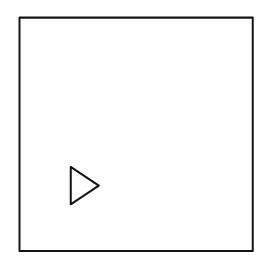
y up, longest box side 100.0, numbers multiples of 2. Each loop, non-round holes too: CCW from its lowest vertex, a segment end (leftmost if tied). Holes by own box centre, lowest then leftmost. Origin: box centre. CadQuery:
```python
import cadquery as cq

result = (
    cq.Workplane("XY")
    .moveTo(-50.0, -50.0)
    .lineTo(50.0, -50.0)
    .lineTo(50.0, 50.0)
    .lineTo(-50.0, 50.0)
    .close()
    .moveTo(-28.0, -30.0)
    .lineTo(-16.0, -22.0)
    .lineTo(-28.0, -14.0)
    .close()
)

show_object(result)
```